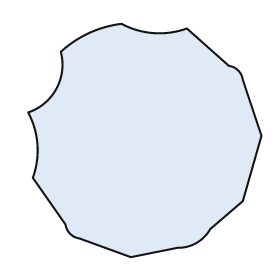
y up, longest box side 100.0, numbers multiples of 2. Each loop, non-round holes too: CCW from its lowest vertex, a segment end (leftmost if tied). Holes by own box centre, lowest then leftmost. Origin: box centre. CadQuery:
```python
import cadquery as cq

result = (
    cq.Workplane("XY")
    .moveTo(-6.0, -50.0)
    .lineTo(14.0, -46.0)
    .threePointArc((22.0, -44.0), (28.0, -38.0))
    .lineTo(42.0, -26.0)
    .lineTo(50.0, 2.0)
    .lineTo(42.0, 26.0)
    .threePointArc((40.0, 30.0), (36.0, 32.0))
    .lineTo(18.0, 48.0)
    .threePointArc((4.0, 46.0), (-10.0, 50.0))
    .threePointArc((-24.0, 46.0), (-36.0, 38.0))
    .threePointArc((-38.0, 22.0), (-50.0, 12.0))
    .threePointArc((-46.0, -2.0), (-48.0, -16.0))
    .lineTo(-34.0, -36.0)
    .threePointArc((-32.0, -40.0), (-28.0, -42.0))
    .close()
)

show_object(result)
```